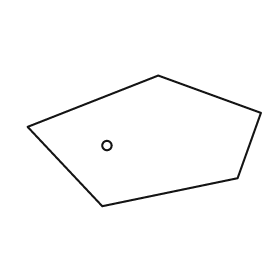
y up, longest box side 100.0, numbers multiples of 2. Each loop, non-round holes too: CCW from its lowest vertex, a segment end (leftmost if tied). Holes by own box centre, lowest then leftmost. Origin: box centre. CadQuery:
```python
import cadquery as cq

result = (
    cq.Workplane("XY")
    .moveTo(-18.0, -28.0)
    .lineTo(40.0, -16.0)
    .lineTo(50.0, 12.0)
    .lineTo(6.0, 28.0)
    .lineTo(-50.0, 6.0)
    .close()
    .moveTo(-16.0, -2.0)
    .circle(2.0)
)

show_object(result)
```